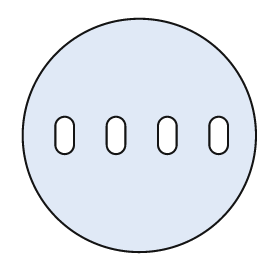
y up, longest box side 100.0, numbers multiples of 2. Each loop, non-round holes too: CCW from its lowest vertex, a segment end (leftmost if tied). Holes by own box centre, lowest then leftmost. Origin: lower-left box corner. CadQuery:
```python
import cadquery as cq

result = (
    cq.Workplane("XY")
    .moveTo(50.0, 50.0)
    .circle(50.0)
    .moveTo(14.0, 46.0)
    .threePointArc((18.0, 42.0), (22.0, 46.0))
    .lineTo(22.0, 54.0)
    .threePointArc((18.0, 58.0), (14.0, 54.0))
    .close()
    .moveTo(36.0, 46.0)
    .threePointArc((40.0, 42.0), (44.0, 46.0))
    .lineTo(44.0, 54.0)
    .threePointArc((40.0, 58.0), (36.0, 54.0))
    .close()
    .moveTo(58.0, 46.0)
    .threePointArc((62.0, 42.0), (66.0, 46.0))
    .lineTo(66.0, 54.0)
    .threePointArc((62.0, 58.0), (58.0, 54.0))
    .close()
    .moveTo(80.0, 46.0)
    .threePointArc((84.0, 42.0), (88.0, 46.0))
    .lineTo(88.0, 54.0)
    .threePointArc((84.0, 58.0), (80.0, 54.0))
    .close()
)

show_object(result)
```